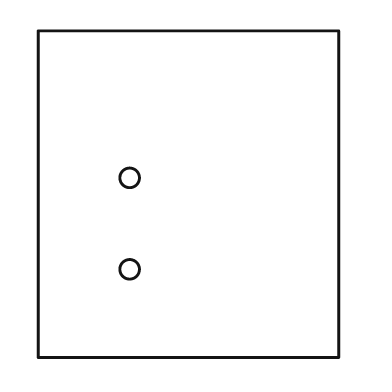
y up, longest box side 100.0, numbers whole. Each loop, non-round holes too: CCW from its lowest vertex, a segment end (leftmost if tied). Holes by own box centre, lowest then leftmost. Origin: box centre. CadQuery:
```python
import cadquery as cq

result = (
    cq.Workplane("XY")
    .moveTo(-46.0, -50.0)
    .lineTo(46.0, -50.0)
    .lineTo(46.0, 50.0)
    .lineTo(-46.0, 50.0)
    .close()
    .moveTo(-18.0, -23.0)
    .circle(3.0)
    .moveTo(-18.0, 5.0)
    .circle(3.0)
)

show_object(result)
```